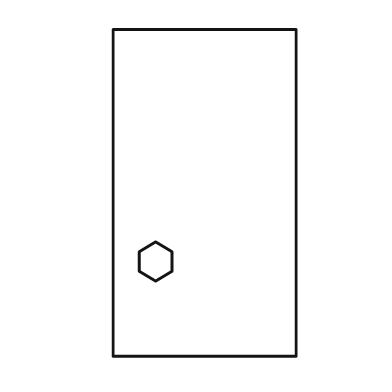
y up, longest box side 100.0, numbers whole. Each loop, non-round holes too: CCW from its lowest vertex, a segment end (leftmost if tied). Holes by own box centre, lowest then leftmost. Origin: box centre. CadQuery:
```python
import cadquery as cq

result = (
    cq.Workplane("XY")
    .moveTo(-28.0, -50.0)
    .lineTo(28.0, -50.0)
    .lineTo(28.0, 50.0)
    .lineTo(-28.0, 50.0)
    .close()
    .moveTo(-15.0, -27.0)
    .lineTo(-10.0, -24.0)
    .lineTo(-10.0, -18.0)
    .lineTo(-15.0, -15.0)
    .lineTo(-20.0, -18.0)
    .lineTo(-20.0, -24.0)
    .close()
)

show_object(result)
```